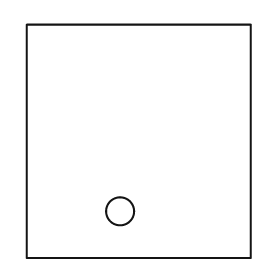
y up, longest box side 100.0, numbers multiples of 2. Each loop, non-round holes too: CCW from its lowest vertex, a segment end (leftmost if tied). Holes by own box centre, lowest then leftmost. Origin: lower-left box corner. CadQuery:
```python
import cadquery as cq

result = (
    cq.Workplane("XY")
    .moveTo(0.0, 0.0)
    .lineTo(96.0, 0.0)
    .lineTo(96.0, 100.0)
    .lineTo(0.0, 100.0)
    .close()
    .moveTo(40.0, 20.0)
    .circle(6.0)
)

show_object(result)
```